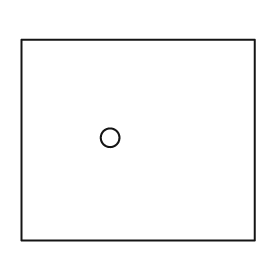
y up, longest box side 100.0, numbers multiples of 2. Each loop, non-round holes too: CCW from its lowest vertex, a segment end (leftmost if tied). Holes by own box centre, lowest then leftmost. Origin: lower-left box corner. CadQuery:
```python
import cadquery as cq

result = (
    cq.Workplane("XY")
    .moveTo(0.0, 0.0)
    .lineTo(100.0, 0.0)
    .lineTo(100.0, 86.0)
    .lineTo(0.0, 86.0)
    .close()
    .moveTo(38.0, 44.0)
    .circle(4.0)
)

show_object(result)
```